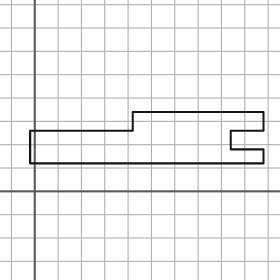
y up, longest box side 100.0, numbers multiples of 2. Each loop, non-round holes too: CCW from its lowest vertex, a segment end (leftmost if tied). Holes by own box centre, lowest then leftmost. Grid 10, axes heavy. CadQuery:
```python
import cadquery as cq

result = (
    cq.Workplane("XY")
    .moveTo(-2.0, 12.0)
    .lineTo(98.0, 12.0)
    .lineTo(98.0, 18.0)
    .lineTo(84.0, 18.0)
    .lineTo(84.0, 26.0)
    .lineTo(98.0, 26.0)
    .lineTo(98.0, 34.0)
    .lineTo(42.0, 34.0)
    .lineTo(42.0, 26.0)
    .lineTo(-2.0, 26.0)
    .close()
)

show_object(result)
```